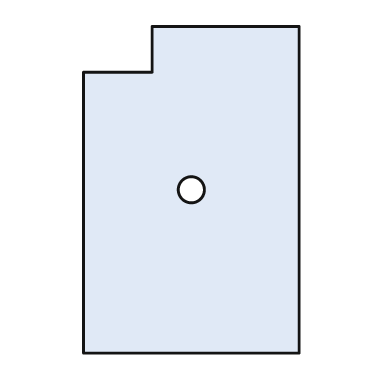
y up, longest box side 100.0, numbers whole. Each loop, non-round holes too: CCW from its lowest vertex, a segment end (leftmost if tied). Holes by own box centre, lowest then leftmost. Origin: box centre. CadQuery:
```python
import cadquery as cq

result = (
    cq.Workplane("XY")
    .moveTo(-33.0, -50.0)
    .lineTo(33.0, -50.0)
    .lineTo(33.0, 50.0)
    .lineTo(-12.0, 50.0)
    .lineTo(-12.0, 36.0)
    .lineTo(-33.0, 36.0)
    .close()
    .moveTo(0.0, 0.0)
    .circle(4.0)
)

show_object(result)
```